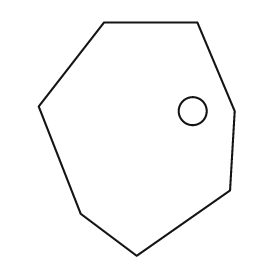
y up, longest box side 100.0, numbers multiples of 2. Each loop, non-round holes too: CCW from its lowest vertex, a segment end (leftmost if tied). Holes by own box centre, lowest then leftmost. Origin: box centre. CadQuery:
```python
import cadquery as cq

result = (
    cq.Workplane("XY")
    .moveTo(0.0, -50.0)
    .lineTo(40.0, -22.0)
    .lineTo(42.0, 12.0)
    .lineTo(26.0, 50.0)
    .lineTo(-14.0, 50.0)
    .lineTo(-42.0, 14.0)
    .lineTo(-24.0, -32.0)
    .close()
    .moveTo(24.0, 12.0)
    .circle(6.0)
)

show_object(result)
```